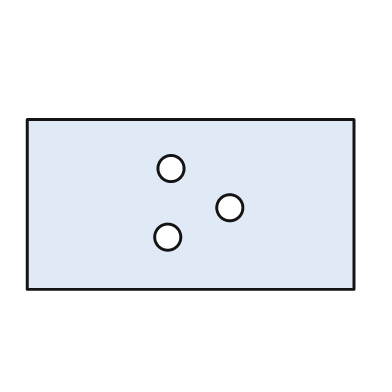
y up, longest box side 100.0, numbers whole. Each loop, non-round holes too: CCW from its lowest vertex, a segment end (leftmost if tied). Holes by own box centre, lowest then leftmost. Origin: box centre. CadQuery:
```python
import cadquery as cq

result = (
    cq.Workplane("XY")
    .moveTo(-50.0, -26.0)
    .lineTo(50.0, -26.0)
    .lineTo(50.0, 26.0)
    .lineTo(-50.0, 26.0)
    .close()
    .moveTo(-7.0, -10.0)
    .circle(4.0)
    .moveTo(12.0, -1.0)
    .circle(4.0)
    .moveTo(-6.0, 11.0)
    .circle(4.0)
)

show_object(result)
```